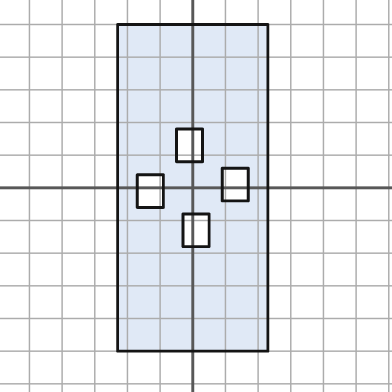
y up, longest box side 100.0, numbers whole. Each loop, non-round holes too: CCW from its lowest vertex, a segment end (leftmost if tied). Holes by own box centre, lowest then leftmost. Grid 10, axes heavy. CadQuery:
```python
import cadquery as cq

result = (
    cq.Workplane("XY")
    .moveTo(-23.0, -50.0)
    .lineTo(23.0, -50.0)
    .lineTo(23.0, 50.0)
    .lineTo(-23.0, 50.0)
    .close()
    .moveTo(-3.0, -18.0)
    .lineTo(5.0, -18.0)
    .lineTo(5.0, -8.0)
    .lineTo(-3.0, -8.0)
    .close()
    .moveTo(-17.0, -6.0)
    .lineTo(-9.0, -6.0)
    .lineTo(-9.0, 4.0)
    .lineTo(-17.0, 4.0)
    .close()
    .moveTo(9.0, -4.0)
    .lineTo(17.0, -4.0)
    .lineTo(17.0, 6.0)
    .lineTo(9.0, 6.0)
    .close()
    .moveTo(-5.0, 8.0)
    .lineTo(3.0, 8.0)
    .lineTo(3.0, 18.0)
    .lineTo(-5.0, 18.0)
    .close()
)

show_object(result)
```